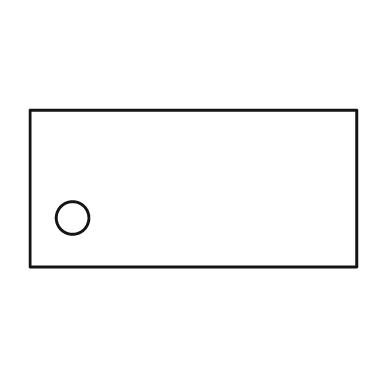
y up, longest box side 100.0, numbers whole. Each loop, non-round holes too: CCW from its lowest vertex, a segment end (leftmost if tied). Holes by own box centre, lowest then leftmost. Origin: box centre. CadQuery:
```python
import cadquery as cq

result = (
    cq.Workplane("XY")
    .moveTo(-50.0, -24.0)
    .lineTo(50.0, -24.0)
    .lineTo(50.0, 24.0)
    .lineTo(-50.0, 24.0)
    .close()
    .moveTo(-37.0, -9.0)
    .circle(5.0)
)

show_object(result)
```